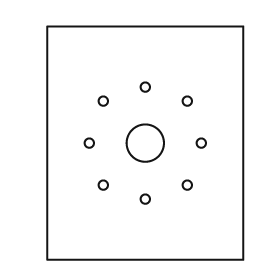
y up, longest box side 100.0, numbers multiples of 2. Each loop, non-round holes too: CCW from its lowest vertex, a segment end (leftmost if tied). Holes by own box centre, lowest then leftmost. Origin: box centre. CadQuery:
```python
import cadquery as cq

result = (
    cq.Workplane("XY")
    .moveTo(-42.0, -50.0)
    .lineTo(42.0, -50.0)
    .lineTo(42.0, 50.0)
    .lineTo(-42.0, 50.0)
    .close()
    .moveTo(0.0, -24.0)
    .circle(2.0)
    .moveTo(-18.0, -18.0)
    .circle(2.0)
    .moveTo(18.0, -18.0)
    .circle(2.0)
    .moveTo(-24.0, 0.0)
    .circle(2.0)
    .moveTo(0.0, 0.0)
    .circle(8.0)
    .moveTo(24.0, 0.0)
    .circle(2.0)
    .moveTo(-18.0, 18.0)
    .circle(2.0)
    .moveTo(18.0, 18.0)
    .circle(2.0)
    .moveTo(0.0, 24.0)
    .circle(2.0)
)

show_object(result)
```